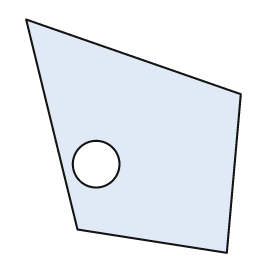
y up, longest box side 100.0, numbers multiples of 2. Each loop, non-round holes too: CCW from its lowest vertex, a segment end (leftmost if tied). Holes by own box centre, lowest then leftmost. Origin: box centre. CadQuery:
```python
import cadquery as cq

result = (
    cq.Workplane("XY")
    .moveTo(40.0, -50.0)
    .lineTo(46.0, 18.0)
    .lineTo(-46.0, 50.0)
    .lineTo(-24.0, -40.0)
    .close()
    .moveTo(-16.0, -12.0)
    .circle(10.0)
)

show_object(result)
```